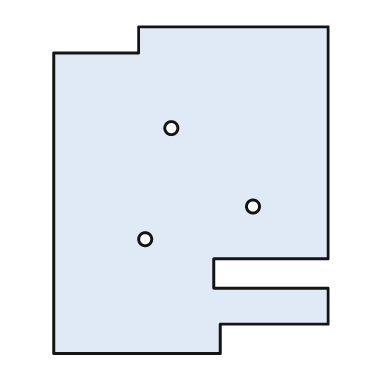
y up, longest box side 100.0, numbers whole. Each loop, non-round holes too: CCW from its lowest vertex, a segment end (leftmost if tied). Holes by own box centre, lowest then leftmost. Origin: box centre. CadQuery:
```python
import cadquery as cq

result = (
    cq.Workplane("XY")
    .moveTo(-42.0, -50.0)
    .lineTo(9.0, -50.0)
    .lineTo(9.0, -41.0)
    .lineTo(42.0, -41.0)
    .lineTo(42.0, -30.0)
    .lineTo(7.0, -30.0)
    .lineTo(7.0, -21.0)
    .lineTo(42.0, -21.0)
    .lineTo(42.0, 50.0)
    .lineTo(-16.0, 50.0)
    .lineTo(-16.0, 42.0)
    .lineTo(-42.0, 42.0)
    .close()
    .moveTo(-14.0, -15.0)
    .circle(2.0)
    .moveTo(19.0, -5.0)
    .circle(2.0)
    .moveTo(-6.0, 19.0)
    .circle(2.0)
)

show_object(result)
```